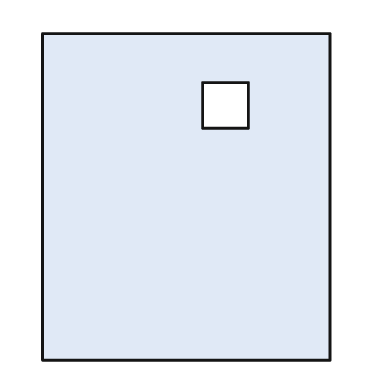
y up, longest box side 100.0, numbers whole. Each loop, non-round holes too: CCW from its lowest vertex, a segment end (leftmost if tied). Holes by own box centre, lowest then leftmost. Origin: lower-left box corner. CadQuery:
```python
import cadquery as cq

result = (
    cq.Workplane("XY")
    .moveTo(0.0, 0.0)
    .lineTo(88.0, 0.0)
    .lineTo(88.0, 100.0)
    .lineTo(0.0, 100.0)
    .close()
    .moveTo(49.0, 71.0)
    .lineTo(63.0, 71.0)
    .lineTo(63.0, 85.0)
    .lineTo(49.0, 85.0)
    .close()
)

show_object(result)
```